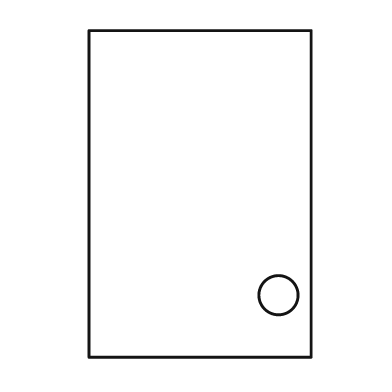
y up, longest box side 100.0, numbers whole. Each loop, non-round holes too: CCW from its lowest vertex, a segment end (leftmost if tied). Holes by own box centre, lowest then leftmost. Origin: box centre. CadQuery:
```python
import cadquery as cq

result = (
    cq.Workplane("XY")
    .moveTo(-34.0, -50.0)
    .lineTo(34.0, -50.0)
    .lineTo(34.0, 50.0)
    .lineTo(-34.0, 50.0)
    .close()
    .moveTo(24.0, -31.0)
    .circle(6.0)
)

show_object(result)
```